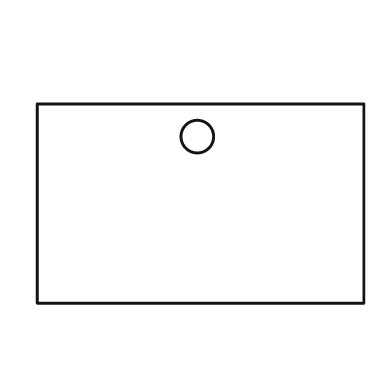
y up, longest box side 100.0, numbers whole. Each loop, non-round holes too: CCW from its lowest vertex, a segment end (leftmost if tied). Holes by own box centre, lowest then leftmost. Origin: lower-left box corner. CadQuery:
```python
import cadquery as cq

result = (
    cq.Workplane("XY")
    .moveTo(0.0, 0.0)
    .lineTo(100.0, 0.0)
    .lineTo(100.0, 61.0)
    .lineTo(0.0, 61.0)
    .close()
    .moveTo(49.0, 51.0)
    .circle(5.0)
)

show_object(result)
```